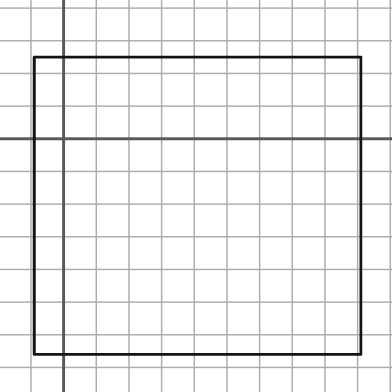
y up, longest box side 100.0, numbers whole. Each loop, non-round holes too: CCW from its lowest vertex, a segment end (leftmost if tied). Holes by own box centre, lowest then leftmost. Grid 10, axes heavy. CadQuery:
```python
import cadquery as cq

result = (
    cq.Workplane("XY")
    .moveTo(-9.0, -66.0)
    .lineTo(91.0, -66.0)
    .lineTo(91.0, 25.0)
    .lineTo(-9.0, 25.0)
    .close()
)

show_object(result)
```